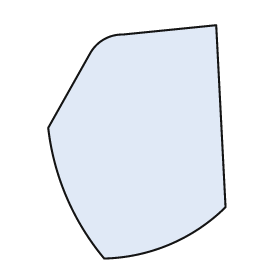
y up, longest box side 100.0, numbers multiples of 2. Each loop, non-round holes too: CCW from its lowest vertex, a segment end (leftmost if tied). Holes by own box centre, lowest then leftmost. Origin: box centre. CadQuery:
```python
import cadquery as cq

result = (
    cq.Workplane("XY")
    .moveTo(-14.0, -50.0)
    .threePointArc((14.0, -44.0), (38.0, -28.0))
    .lineTo(34.0, 50.0)
    .lineTo(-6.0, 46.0)
    .threePointArc((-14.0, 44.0), (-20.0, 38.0))
    .lineTo(-38.0, 6.0)
    .threePointArc((-30.0, -24.0), (-14.0, -50.0))
    .close()
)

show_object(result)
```